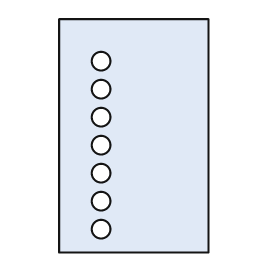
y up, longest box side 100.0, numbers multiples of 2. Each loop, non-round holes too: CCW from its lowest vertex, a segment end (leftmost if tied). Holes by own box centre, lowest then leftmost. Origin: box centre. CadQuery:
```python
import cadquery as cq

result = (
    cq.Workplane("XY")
    .moveTo(-32.0, -50.0)
    .lineTo(32.0, -50.0)
    .lineTo(32.0, 50.0)
    .lineTo(-32.0, 50.0)
    .close()
    .moveTo(-14.0, -40.0)
    .circle(4.0)
    .moveTo(-14.0, -28.0)
    .circle(4.0)
    .moveTo(-14.0, -16.0)
    .circle(4.0)
    .moveTo(-14.0, -4.0)
    .circle(4.0)
    .moveTo(-14.0, 8.0)
    .circle(4.0)
    .moveTo(-14.0, 20.0)
    .circle(4.0)
    .moveTo(-14.0, 32.0)
    .circle(4.0)
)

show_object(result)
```